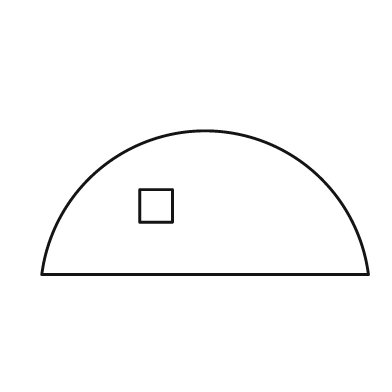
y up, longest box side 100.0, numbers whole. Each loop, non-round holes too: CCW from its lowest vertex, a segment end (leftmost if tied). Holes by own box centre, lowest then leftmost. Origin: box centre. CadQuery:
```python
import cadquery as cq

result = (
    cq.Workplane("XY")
    .moveTo(-50.0, -22.0)
    .lineTo(50.0, -22.0)
    .threePointArc((0.0, 22.0), (-50.0, -22.0))
    .close()
    .moveTo(-20.0, -6.0)
    .lineTo(-10.0, -6.0)
    .lineTo(-10.0, 4.0)
    .lineTo(-20.0, 4.0)
    .close()
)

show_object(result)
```